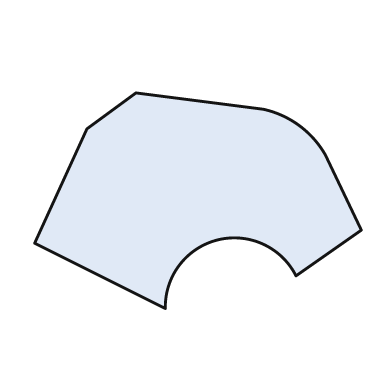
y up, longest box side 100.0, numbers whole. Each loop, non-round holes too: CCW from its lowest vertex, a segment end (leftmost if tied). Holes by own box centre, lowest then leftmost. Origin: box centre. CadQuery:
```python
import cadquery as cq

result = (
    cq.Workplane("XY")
    .moveTo(-10.0, -33.0)
    .threePointArc((6.0, -12.0), (30.0, -23.0))
    .lineTo(50.0, -9.0)
    .lineTo(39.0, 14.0)
    .threePointArc((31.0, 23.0), (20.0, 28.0))
    .lineTo(-19.0, 33.0)
    .lineTo(-34.0, 22.0)
    .lineTo(-50.0, -13.0)
    .close()
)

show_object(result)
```